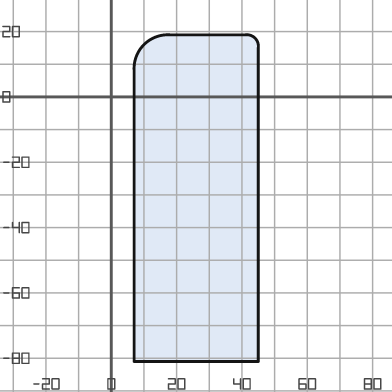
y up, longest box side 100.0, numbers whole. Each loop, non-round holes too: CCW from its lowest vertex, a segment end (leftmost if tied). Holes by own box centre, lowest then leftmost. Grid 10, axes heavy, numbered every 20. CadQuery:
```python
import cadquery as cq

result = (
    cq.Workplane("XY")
    .moveTo(7.0, -81.0)
    .lineTo(45.0, -81.0)
    .lineTo(45.0, 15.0)
    .threePointArc((44.0, 18.0), (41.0, 19.0))
    .lineTo(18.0, 19.0)
    .threePointArc((10.0, 16.0), (7.0, 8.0))
    .close()
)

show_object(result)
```